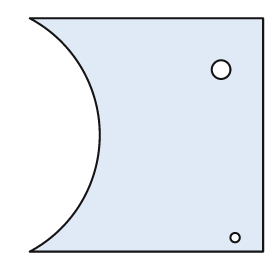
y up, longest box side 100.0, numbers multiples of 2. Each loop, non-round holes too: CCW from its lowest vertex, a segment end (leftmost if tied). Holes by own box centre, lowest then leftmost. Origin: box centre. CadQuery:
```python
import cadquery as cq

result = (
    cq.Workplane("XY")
    .moveTo(-50.0, -50.0)
    .lineTo(50.0, -50.0)
    .lineTo(50.0, 50.0)
    .lineTo(-50.0, 50.0)
    .threePointArc((-20.0, 0.0), (-50.0, -50.0))
    .close()
    .moveTo(38.0, -44.0)
    .circle(2.0)
    .moveTo(32.0, 28.0)
    .circle(4.0)
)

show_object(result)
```